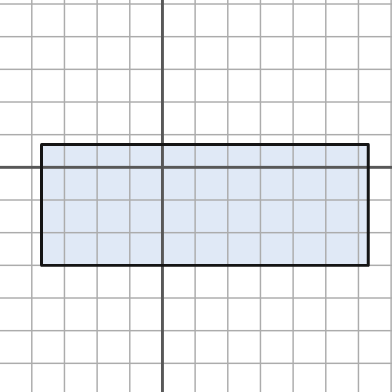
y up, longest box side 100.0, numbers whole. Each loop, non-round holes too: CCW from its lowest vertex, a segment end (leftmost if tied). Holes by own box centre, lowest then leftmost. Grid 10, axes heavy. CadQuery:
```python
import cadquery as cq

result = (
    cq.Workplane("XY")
    .moveTo(-37.0, -30.0)
    .lineTo(63.0, -30.0)
    .lineTo(63.0, 7.0)
    .lineTo(-37.0, 7.0)
    .close()
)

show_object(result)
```